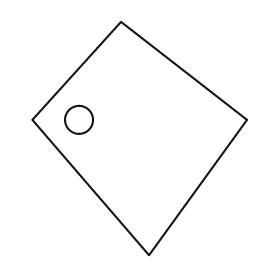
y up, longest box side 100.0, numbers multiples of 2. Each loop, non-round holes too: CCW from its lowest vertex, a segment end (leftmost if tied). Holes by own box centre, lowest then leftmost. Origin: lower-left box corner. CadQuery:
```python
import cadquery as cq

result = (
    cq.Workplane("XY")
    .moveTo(50.0, 0.0)
    .lineTo(92.0, 58.0)
    .lineTo(38.0, 100.0)
    .lineTo(0.0, 58.0)
    .close()
    .moveTo(20.0, 58.0)
    .circle(6.0)
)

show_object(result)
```